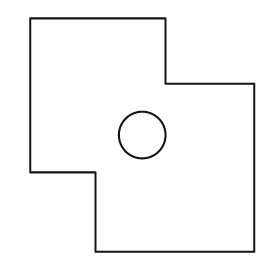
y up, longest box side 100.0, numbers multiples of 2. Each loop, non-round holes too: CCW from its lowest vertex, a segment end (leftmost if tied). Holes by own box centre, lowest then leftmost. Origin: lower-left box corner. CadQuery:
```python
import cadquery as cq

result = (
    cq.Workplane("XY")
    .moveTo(28.0, 0.0)
    .lineTo(96.0, 0.0)
    .lineTo(96.0, 72.0)
    .lineTo(58.0, 72.0)
    .lineTo(58.0, 100.0)
    .lineTo(0.0, 100.0)
    .lineTo(0.0, 34.0)
    .lineTo(28.0, 34.0)
    .close()
    .moveTo(48.0, 50.0)
    .circle(10.0)
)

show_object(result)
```